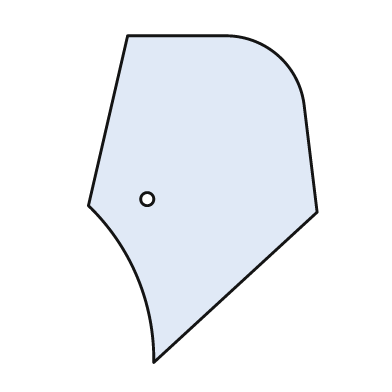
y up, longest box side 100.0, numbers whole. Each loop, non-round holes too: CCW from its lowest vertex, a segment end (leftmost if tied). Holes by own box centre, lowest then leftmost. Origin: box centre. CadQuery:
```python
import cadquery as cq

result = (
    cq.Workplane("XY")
    .moveTo(-15.0, -50.0)
    .lineTo(35.0, -4.0)
    .lineTo(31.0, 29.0)
    .threePointArc((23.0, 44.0), (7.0, 50.0))
    .lineTo(-23.0, 50.0)
    .lineTo(-35.0, -2.0)
    .threePointArc((-20.0, -24.0), (-15.0, -50.0))
    .close()
    .moveTo(-17.0, 0.0)
    .circle(2.0)
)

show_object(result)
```